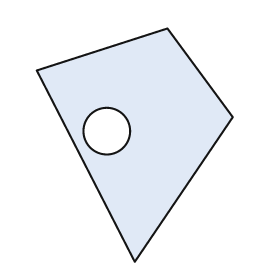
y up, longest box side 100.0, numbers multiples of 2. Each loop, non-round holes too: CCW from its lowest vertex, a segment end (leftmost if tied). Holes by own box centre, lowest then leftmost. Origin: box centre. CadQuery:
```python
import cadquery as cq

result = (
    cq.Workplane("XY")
    .moveTo(0.0, -50.0)
    .lineTo(42.0, 12.0)
    .lineTo(14.0, 50.0)
    .lineTo(-42.0, 32.0)
    .close()
    .moveTo(-12.0, 6.0)
    .circle(10.0)
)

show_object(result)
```